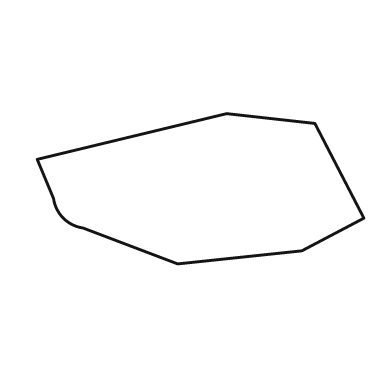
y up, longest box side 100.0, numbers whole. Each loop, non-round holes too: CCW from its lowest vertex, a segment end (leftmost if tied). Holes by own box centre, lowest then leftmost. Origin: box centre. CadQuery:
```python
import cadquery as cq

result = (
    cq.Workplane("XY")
    .moveTo(-7.0, -23.0)
    .lineTo(31.0, -19.0)
    .lineTo(50.0, -9.0)
    .lineTo(35.0, 20.0)
    .lineTo(8.0, 23.0)
    .lineTo(-50.0, 9.0)
    .lineTo(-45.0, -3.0)
    .threePointArc((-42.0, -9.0), (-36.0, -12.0))
    .close()
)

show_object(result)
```